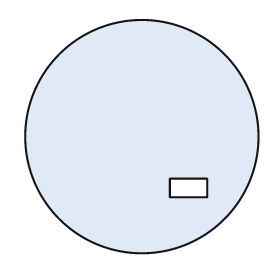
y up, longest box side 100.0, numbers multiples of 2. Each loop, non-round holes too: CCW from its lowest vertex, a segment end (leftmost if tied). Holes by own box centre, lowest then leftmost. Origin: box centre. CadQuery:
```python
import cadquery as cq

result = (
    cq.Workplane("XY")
    .moveTo(0.0, 0.0)
    .circle(50.0)
    .moveTo(12.0, -26.0)
    .lineTo(28.0, -26.0)
    .lineTo(28.0, -18.0)
    .lineTo(12.0, -18.0)
    .close()
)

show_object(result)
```